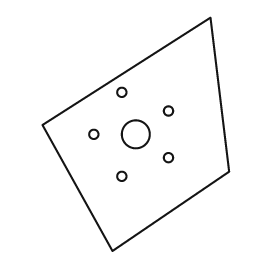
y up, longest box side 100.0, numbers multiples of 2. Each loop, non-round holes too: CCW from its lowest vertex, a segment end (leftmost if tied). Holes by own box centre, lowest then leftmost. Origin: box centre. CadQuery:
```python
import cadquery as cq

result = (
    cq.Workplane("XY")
    .moveTo(-10.0, -50.0)
    .lineTo(40.0, -16.0)
    .lineTo(32.0, 50.0)
    .lineTo(-40.0, 4.0)
    .close()
    .moveTo(-6.0, -18.0)
    .circle(2.0)
    .moveTo(14.0, -10.0)
    .circle(2.0)
    .moveTo(-18.0, 0.0)
    .circle(2.0)
    .moveTo(0.0, 0.0)
    .circle(6.0)
    .moveTo(14.0, 10.0)
    .circle(2.0)
    .moveTo(-6.0, 18.0)
    .circle(2.0)
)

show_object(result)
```